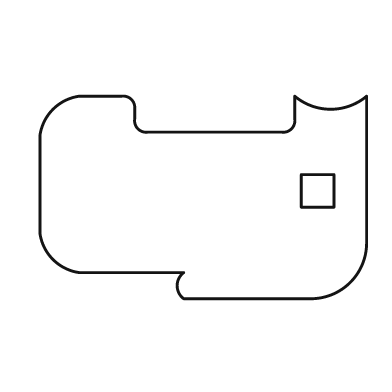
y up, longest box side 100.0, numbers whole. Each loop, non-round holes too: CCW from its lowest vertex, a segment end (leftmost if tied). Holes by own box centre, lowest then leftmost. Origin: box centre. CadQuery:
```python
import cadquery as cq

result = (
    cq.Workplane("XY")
    .moveTo(-6.0, -31.0)
    .lineTo(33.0, -31.0)
    .threePointArc((45.0, -26.0), (50.0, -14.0))
    .lineTo(50.0, 31.0)
    .threePointArc((39.0, 27.0), (28.0, 31.0))
    .lineTo(28.0, 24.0)
    .threePointArc((27.0, 21.0), (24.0, 20.0))
    .lineTo(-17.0, 20.0)
    .threePointArc((-20.0, 21.0), (-21.0, 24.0))
    .lineTo(-21.0, 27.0)
    .threePointArc((-22.0, 30.0), (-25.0, 31.0))
    .lineTo(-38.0, 31.0)
    .threePointArc((-46.0, 27.0), (-50.0, 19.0))
    .lineTo(-50.0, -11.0)
    .threePointArc((-46.0, -19.0), (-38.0, -23.0))
    .lineTo(-6.0, -23.0)
    .threePointArc((-8.0, -27.0), (-6.0, -31.0))
    .close()
    .moveTo(30.0, -3.0)
    .lineTo(40.0, -3.0)
    .lineTo(40.0, 7.0)
    .lineTo(30.0, 7.0)
    .close()
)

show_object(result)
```